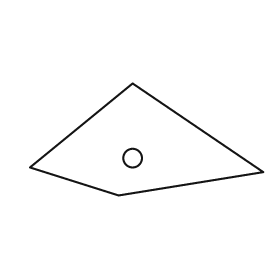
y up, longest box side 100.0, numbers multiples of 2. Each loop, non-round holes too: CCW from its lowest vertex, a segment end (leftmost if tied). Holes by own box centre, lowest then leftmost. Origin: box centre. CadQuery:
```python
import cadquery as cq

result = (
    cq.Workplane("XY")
    .moveTo(-12.0, -24.0)
    .lineTo(50.0, -14.0)
    .lineTo(-6.0, 24.0)
    .lineTo(-50.0, -12.0)
    .close()
    .moveTo(-6.0, -8.0)
    .circle(4.0)
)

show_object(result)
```